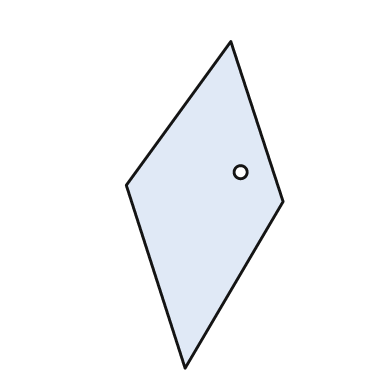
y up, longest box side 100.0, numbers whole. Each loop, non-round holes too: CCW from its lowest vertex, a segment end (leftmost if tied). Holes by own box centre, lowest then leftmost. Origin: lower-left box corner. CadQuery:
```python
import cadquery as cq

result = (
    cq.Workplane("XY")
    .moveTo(18.0, 0.0)
    .lineTo(48.0, 51.0)
    .lineTo(32.0, 100.0)
    .lineTo(0.0, 56.0)
    .close()
    .moveTo(35.0, 60.0)
    .circle(2.0)
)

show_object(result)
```